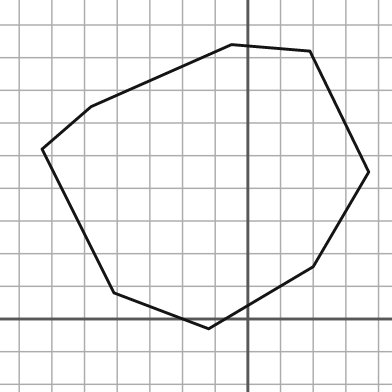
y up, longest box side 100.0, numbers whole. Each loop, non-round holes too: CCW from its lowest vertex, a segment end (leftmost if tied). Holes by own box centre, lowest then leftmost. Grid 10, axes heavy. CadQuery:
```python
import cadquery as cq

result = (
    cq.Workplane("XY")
    .moveTo(-12.0, -3.0)
    .lineTo(20.0, 16.0)
    .lineTo(37.0, 45.0)
    .lineTo(19.0, 82.0)
    .lineTo(-5.0, 84.0)
    .lineTo(-48.0, 65.0)
    .lineTo(-63.0, 52.0)
    .lineTo(-41.0, 8.0)
    .close()
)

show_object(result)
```